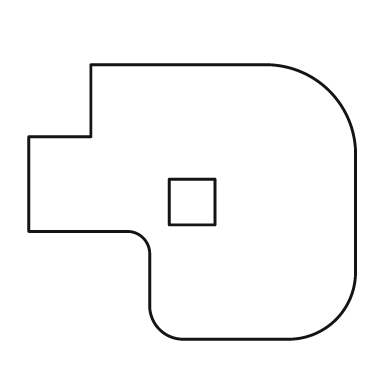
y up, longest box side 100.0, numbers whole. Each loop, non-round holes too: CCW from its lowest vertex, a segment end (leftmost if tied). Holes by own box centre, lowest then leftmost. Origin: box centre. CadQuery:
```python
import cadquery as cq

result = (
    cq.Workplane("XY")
    .moveTo(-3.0, -42.0)
    .lineTo(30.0, -42.0)
    .threePointArc((44.0, -36.0), (50.0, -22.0))
    .lineTo(50.0, 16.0)
    .threePointArc((42.0, 34.0), (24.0, 42.0))
    .lineTo(-31.0, 42.0)
    .lineTo(-31.0, 20.0)
    .lineTo(-50.0, 20.0)
    .lineTo(-50.0, -9.0)
    .lineTo(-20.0, -9.0)
    .threePointArc((-15.0, -11.0), (-13.0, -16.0))
    .lineTo(-13.0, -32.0)
    .threePointArc((-10.0, -39.0), (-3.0, -42.0))
    .close()
    .moveTo(-7.0, -7.0)
    .lineTo(7.0, -7.0)
    .lineTo(7.0, 7.0)
    .lineTo(-7.0, 7.0)
    .close()
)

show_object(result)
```